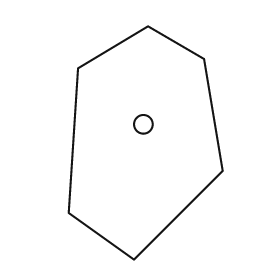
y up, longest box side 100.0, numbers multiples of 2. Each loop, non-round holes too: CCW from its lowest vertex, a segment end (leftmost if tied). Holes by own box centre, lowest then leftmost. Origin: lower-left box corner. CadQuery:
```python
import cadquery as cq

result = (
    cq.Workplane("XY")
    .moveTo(28.0, 0.0)
    .lineTo(66.0, 38.0)
    .lineTo(58.0, 86.0)
    .lineTo(34.0, 100.0)
    .lineTo(4.0, 82.0)
    .lineTo(0.0, 20.0)
    .close()
    .moveTo(32.0, 58.0)
    .circle(4.0)
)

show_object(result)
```